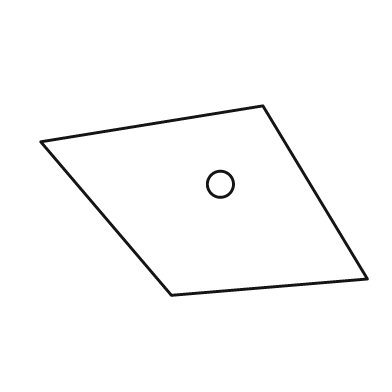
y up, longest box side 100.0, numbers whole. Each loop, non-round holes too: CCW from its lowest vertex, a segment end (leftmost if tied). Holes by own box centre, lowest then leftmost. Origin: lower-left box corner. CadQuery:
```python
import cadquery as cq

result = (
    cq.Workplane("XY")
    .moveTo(40.0, 0.0)
    .lineTo(100.0, 5.0)
    .lineTo(68.0, 58.0)
    .lineTo(0.0, 47.0)
    .close()
    .moveTo(55.0, 34.0)
    .circle(4.0)
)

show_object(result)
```